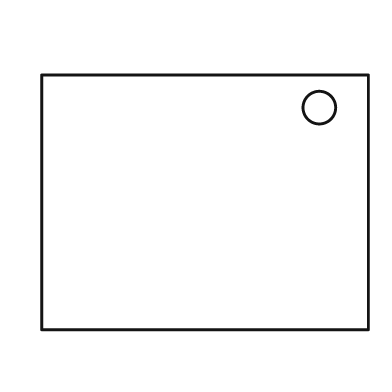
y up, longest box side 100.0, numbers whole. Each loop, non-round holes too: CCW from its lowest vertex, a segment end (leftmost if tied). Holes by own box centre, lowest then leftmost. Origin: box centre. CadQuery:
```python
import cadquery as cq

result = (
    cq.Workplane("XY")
    .moveTo(-50.0, -39.0)
    .lineTo(50.0, -39.0)
    .lineTo(50.0, 39.0)
    .lineTo(-50.0, 39.0)
    .close()
    .moveTo(35.0, 29.0)
    .circle(5.0)
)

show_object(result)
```